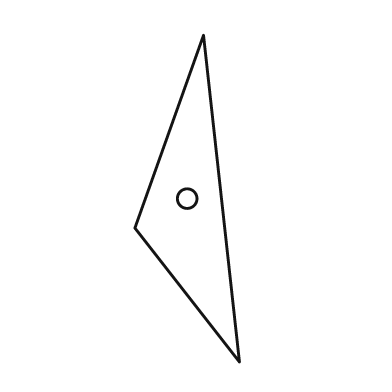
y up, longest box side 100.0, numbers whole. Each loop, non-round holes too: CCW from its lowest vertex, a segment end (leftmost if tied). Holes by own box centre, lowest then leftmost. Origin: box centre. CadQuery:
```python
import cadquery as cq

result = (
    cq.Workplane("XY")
    .moveTo(16.0, -50.0)
    .lineTo(5.0, 50.0)
    .lineTo(-16.0, -9.0)
    .close()
    .moveTo(0.0, 0.0)
    .circle(3.0)
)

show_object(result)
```